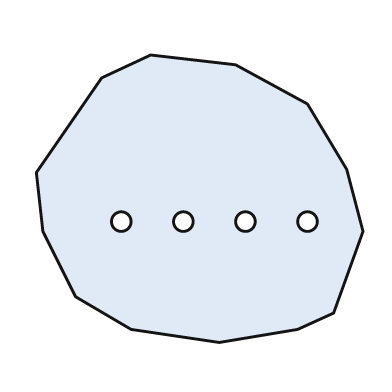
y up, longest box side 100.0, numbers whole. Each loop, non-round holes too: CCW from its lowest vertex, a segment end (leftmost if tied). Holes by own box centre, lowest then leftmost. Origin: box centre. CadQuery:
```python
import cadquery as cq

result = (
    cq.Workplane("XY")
    .moveTo(6.0, -44.0)
    .lineTo(30.0, -40.0)
    .lineTo(41.0, -35.0)
    .lineTo(50.0, -10.0)
    .lineTo(45.0, 9.0)
    .lineTo(33.0, 29.0)
    .lineTo(11.0, 41.0)
    .lineTo(-15.0, 44.0)
    .lineTo(-30.0, 37.0)
    .lineTo(-50.0, 8.0)
    .lineTo(-48.0, -10.0)
    .lineTo(-38.0, -30.0)
    .lineTo(-21.0, -40.0)
    .close()
    .moveTo(-24.0, -7.0)
    .circle(3.0)
    .moveTo(-5.0, -7.0)
    .circle(3.0)
    .moveTo(14.0, -7.0)
    .circle(3.0)
    .moveTo(33.0, -7.0)
    .circle(3.0)
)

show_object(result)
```